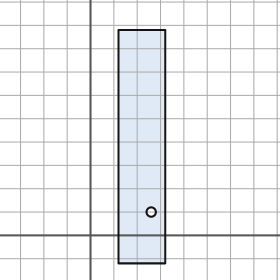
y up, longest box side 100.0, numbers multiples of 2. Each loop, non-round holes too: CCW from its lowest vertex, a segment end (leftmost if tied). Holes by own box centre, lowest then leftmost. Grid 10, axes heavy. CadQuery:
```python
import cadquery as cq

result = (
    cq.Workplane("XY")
    .moveTo(12.0, -12.0)
    .lineTo(32.0, -12.0)
    .lineTo(32.0, 88.0)
    .lineTo(12.0, 88.0)
    .close()
    .moveTo(26.0, 10.0)
    .circle(2.0)
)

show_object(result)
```